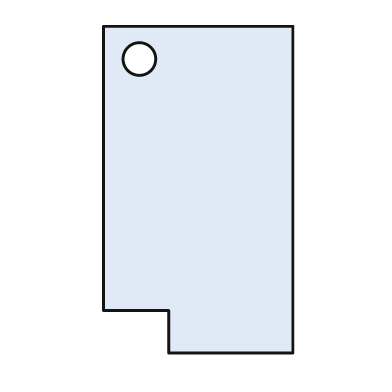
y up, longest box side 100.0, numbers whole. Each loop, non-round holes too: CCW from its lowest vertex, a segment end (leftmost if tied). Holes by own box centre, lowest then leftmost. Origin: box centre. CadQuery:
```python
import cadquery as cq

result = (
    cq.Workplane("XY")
    .moveTo(-9.0, -50.0)
    .lineTo(29.0, -50.0)
    .lineTo(29.0, 50.0)
    .lineTo(-29.0, 50.0)
    .lineTo(-29.0, -37.0)
    .lineTo(-9.0, -37.0)
    .close()
    .moveTo(-18.0, 40.0)
    .circle(5.0)
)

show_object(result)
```